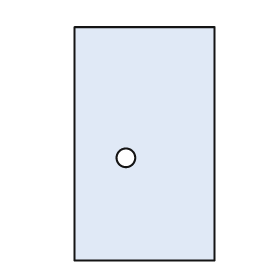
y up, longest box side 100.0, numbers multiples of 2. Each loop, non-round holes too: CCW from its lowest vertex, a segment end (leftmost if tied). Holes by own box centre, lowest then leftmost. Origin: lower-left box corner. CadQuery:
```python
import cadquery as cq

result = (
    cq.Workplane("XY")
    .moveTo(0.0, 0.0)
    .lineTo(60.0, 0.0)
    .lineTo(60.0, 100.0)
    .lineTo(0.0, 100.0)
    .close()
    .moveTo(22.0, 44.0)
    .circle(4.0)
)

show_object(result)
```